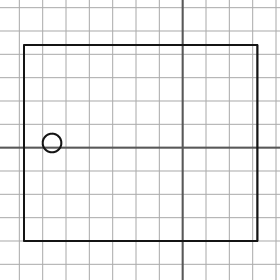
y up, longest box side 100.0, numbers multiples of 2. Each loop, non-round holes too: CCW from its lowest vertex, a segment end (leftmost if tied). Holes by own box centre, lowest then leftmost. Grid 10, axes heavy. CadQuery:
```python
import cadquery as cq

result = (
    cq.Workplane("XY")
    .moveTo(-68.0, -40.0)
    .lineTo(32.0, -40.0)
    .lineTo(32.0, 44.0)
    .lineTo(-68.0, 44.0)
    .close()
    .moveTo(-56.0, 2.0)
    .circle(4.0)
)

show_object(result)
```